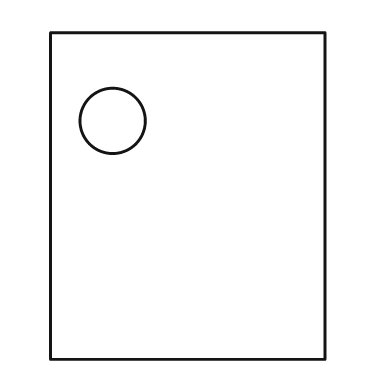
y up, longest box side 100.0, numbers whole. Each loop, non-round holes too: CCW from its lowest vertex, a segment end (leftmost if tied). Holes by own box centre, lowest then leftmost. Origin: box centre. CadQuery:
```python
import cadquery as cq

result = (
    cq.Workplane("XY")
    .moveTo(-42.0, -50.0)
    .lineTo(42.0, -50.0)
    .lineTo(42.0, 50.0)
    .lineTo(-42.0, 50.0)
    .close()
    .moveTo(-23.0, 23.0)
    .circle(10.0)
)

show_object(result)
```